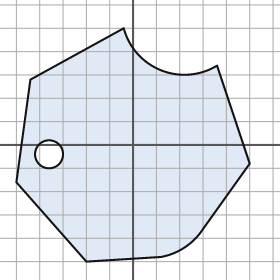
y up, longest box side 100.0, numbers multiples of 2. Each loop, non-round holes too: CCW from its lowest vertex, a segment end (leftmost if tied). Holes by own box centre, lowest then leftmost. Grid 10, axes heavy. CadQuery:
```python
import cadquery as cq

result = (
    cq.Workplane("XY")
    .moveTo(-20.0, -50.0)
    .lineTo(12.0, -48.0)
    .threePointArc((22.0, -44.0), (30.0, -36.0))
    .lineTo(50.0, -8.0)
    .lineTo(36.0, 34.0)
    .threePointArc((12.0, 32.0), (-4.0, 50.0))
    .lineTo(-44.0, 28.0)
    .lineTo(-50.0, -16.0)
    .close()
    .moveTo(-36.0, -4.0)
    .circle(6.0)
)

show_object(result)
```